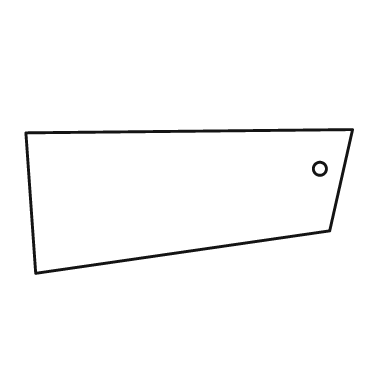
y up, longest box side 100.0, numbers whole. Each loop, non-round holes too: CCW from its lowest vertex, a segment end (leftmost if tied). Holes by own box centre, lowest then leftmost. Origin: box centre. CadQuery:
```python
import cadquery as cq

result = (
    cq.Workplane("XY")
    .moveTo(-47.0, -22.0)
    .lineTo(43.0, -9.0)
    .lineTo(50.0, 22.0)
    .lineTo(-50.0, 21.0)
    .close()
    .moveTo(40.0, 10.0)
    .circle(2.0)
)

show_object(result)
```